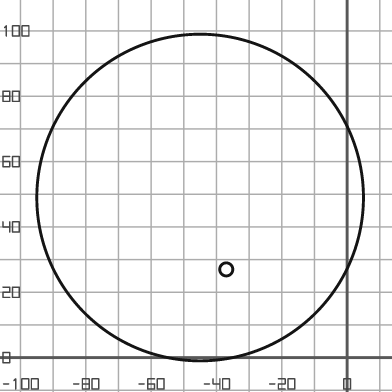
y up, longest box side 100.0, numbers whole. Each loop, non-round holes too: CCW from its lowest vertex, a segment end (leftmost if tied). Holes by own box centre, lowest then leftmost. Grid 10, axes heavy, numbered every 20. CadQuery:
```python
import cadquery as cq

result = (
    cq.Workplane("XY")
    .moveTo(-45.0, 49.0)
    .circle(50.0)
    .moveTo(-37.0, 27.0)
    .circle(2.0)
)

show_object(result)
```